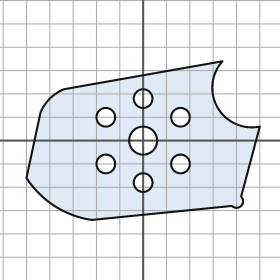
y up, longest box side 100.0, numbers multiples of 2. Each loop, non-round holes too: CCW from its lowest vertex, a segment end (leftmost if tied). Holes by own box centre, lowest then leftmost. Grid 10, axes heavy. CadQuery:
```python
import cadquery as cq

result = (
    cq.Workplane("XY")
    .moveTo(-22.0, -34.0)
    .lineTo(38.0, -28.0)
    .threePointArc((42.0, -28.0), (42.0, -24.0))
    .lineTo(50.0, 6.0)
    .threePointArc((32.0, 14.0), (34.0, 34.0))
    .lineTo(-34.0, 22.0)
    .threePointArc((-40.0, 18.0), (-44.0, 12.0))
    .lineTo(-50.0, -16.0)
    .threePointArc((-38.0, -28.0), (-22.0, -34.0))
    .close()
    .moveTo(0.0, -18.0)
    .circle(4.0)
    .moveTo(-16.0, -10.0)
    .circle(4.0)
    .moveTo(16.0, -10.0)
    .circle(4.0)
    .moveTo(0.0, 0.0)
    .circle(6.0)
    .moveTo(-16.0, 10.0)
    .circle(4.0)
    .moveTo(16.0, 10.0)
    .circle(4.0)
    .moveTo(0.0, 18.0)
    .circle(4.0)
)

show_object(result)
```